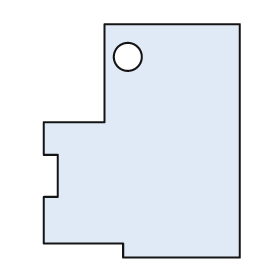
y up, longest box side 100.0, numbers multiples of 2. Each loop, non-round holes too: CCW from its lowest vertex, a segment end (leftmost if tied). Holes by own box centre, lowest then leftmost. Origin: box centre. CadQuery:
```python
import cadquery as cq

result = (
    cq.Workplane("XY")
    .moveTo(-8.0, -50.0)
    .lineTo(42.0, -50.0)
    .lineTo(42.0, 50.0)
    .lineTo(-16.0, 50.0)
    .lineTo(-16.0, 8.0)
    .lineTo(-42.0, 8.0)
    .lineTo(-42.0, -6.0)
    .lineTo(-36.0, -6.0)
    .lineTo(-36.0, -24.0)
    .lineTo(-42.0, -24.0)
    .lineTo(-42.0, -44.0)
    .lineTo(-8.0, -44.0)
    .close()
    .moveTo(-6.0, 36.0)
    .circle(6.0)
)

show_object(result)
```